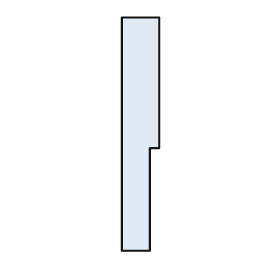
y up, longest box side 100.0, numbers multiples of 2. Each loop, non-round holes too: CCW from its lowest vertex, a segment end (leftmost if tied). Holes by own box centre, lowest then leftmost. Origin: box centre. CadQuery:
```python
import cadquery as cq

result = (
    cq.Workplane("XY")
    .moveTo(-8.0, -50.0)
    .lineTo(4.0, -50.0)
    .lineTo(4.0, -6.0)
    .lineTo(8.0, -6.0)
    .lineTo(8.0, 50.0)
    .lineTo(-8.0, 50.0)
    .close()
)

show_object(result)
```